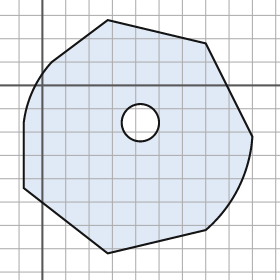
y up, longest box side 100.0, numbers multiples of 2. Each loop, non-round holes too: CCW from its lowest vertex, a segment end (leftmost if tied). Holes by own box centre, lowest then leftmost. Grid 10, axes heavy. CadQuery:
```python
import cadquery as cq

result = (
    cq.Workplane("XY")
    .moveTo(28.0, -72.0)
    .lineTo(70.0, -62.0)
    .threePointArc((84.0, -44.0), (90.0, -22.0))
    .lineTo(70.0, 18.0)
    .lineTo(28.0, 28.0)
    .lineTo(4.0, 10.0)
    .threePointArc((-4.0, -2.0), (-8.0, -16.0))
    .lineTo(-8.0, -44.0)
    .close()
    .moveTo(42.0, -16.0)
    .circle(8.0)
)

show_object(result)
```